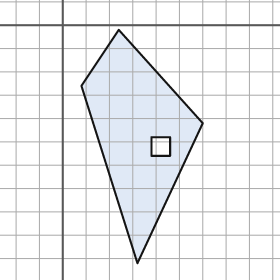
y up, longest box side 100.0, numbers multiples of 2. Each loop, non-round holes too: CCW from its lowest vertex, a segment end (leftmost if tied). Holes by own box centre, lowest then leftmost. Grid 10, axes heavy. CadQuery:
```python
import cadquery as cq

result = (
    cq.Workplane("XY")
    .moveTo(32.0, -102.0)
    .lineTo(60.0, -42.0)
    .lineTo(24.0, -2.0)
    .lineTo(8.0, -26.0)
    .close()
    .moveTo(38.0, -56.0)
    .lineTo(46.0, -56.0)
    .lineTo(46.0, -48.0)
    .lineTo(38.0, -48.0)
    .close()
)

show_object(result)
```